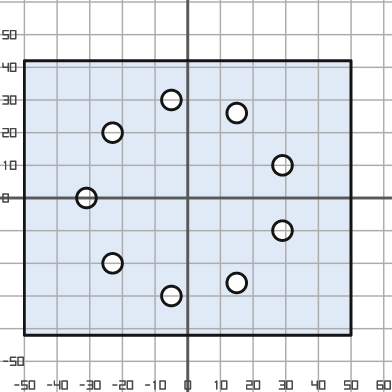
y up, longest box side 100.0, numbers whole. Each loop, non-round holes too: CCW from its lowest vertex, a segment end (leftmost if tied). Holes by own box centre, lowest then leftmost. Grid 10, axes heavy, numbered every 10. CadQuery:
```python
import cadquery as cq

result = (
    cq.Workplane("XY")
    .moveTo(-50.0, -42.0)
    .lineTo(50.0, -42.0)
    .lineTo(50.0, 42.0)
    .lineTo(-50.0, 42.0)
    .close()
    .moveTo(-5.0, -30.0)
    .circle(3.0)
    .moveTo(15.0, -26.0)
    .circle(3.0)
    .moveTo(-23.0, -20.0)
    .circle(3.0)
    .moveTo(29.0, -10.0)
    .circle(3.0)
    .moveTo(-31.0, 0.0)
    .circle(3.0)
    .moveTo(29.0, 10.0)
    .circle(3.0)
    .moveTo(-23.0, 20.0)
    .circle(3.0)
    .moveTo(15.0, 26.0)
    .circle(3.0)
    .moveTo(-5.0, 30.0)
    .circle(3.0)
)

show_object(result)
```